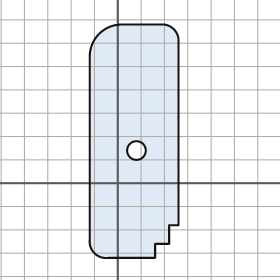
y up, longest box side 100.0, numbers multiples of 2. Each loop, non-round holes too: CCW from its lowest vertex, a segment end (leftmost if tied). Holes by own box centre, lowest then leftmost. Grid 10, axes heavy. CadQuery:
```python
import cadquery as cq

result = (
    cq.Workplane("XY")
    .moveTo(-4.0, -32.0)
    .lineTo(16.0, -32.0)
    .lineTo(16.0, -26.0)
    .lineTo(22.0, -26.0)
    .lineTo(22.0, -18.0)
    .lineTo(26.0, -18.0)
    .lineTo(26.0, 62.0)
    .threePointArc((24.0, 66.0), (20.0, 68.0))
    .lineTo(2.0, 68.0)
    .threePointArc((-8.0, 64.0), (-12.0, 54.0))
    .lineTo(-12.0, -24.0)
    .threePointArc((-10.0, -30.0), (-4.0, -32.0))
    .close()
    .moveTo(8.0, 14.0)
    .circle(4.0)
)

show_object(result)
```